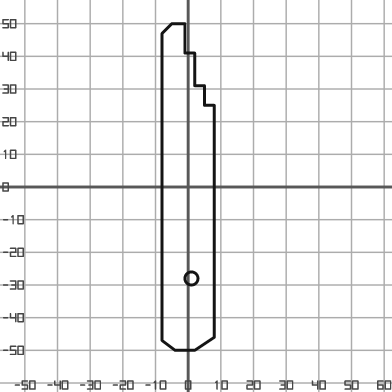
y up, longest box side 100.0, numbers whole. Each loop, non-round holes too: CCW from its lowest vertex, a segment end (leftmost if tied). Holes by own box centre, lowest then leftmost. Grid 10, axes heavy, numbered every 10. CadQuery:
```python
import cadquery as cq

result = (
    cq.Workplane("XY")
    .moveTo(-4.0, -50.0)
    .lineTo(2.0, -50.0)
    .lineTo(8.0, -46.0)
    .lineTo(8.0, 25.0)
    .lineTo(5.0, 25.0)
    .lineTo(5.0, 31.0)
    .lineTo(2.0, 31.0)
    .lineTo(2.0, 41.0)
    .lineTo(-1.0, 41.0)
    .lineTo(-1.0, 50.0)
    .lineTo(-5.0, 50.0)
    .lineTo(-8.0, 47.0)
    .lineTo(-8.0, -47.0)
    .close()
    .moveTo(1.0, -28.0)
    .circle(2.0)
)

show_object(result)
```